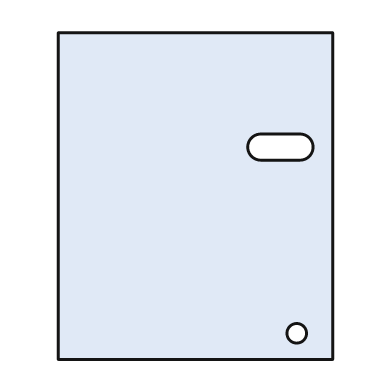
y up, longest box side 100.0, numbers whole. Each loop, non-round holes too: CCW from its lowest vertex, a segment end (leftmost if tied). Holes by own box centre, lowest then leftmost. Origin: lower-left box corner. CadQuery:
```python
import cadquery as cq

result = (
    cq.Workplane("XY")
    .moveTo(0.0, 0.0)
    .lineTo(84.0, 0.0)
    .lineTo(84.0, 100.0)
    .lineTo(0.0, 100.0)
    .close()
    .moveTo(73.0, 8.0)
    .circle(3.0)
    .moveTo(62.0, 61.0)
    .lineTo(74.0, 61.0)
    .threePointArc((78.0, 65.0), (74.0, 69.0))
    .lineTo(62.0, 69.0)
    .threePointArc((58.0, 65.0), (62.0, 61.0))
    .close()
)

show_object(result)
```